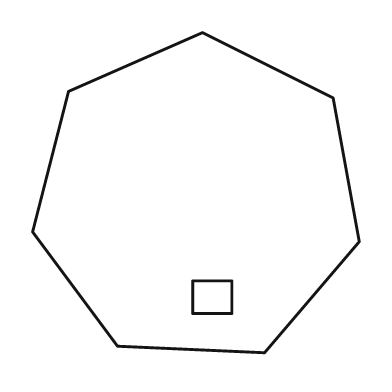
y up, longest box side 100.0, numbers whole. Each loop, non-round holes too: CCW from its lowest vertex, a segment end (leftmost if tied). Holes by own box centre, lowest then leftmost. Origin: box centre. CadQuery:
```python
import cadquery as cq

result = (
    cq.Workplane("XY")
    .moveTo(21.0, -49.0)
    .lineTo(50.0, -15.0)
    .lineTo(42.0, 29.0)
    .lineTo(2.0, 49.0)
    .lineTo(-39.0, 31.0)
    .lineTo(-50.0, -12.0)
    .lineTo(-24.0, -47.0)
    .close()
    .moveTo(-1.0, -37.0)
    .lineTo(11.0, -37.0)
    .lineTo(11.0, -27.0)
    .lineTo(-1.0, -27.0)
    .close()
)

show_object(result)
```